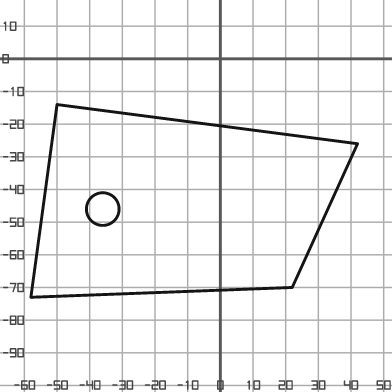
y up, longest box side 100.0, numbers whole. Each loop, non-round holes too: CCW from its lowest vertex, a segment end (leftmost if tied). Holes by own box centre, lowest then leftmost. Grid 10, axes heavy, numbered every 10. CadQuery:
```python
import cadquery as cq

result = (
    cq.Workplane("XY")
    .moveTo(-58.0, -73.0)
    .lineTo(22.0, -70.0)
    .lineTo(42.0, -26.0)
    .lineTo(-50.0, -14.0)
    .close()
    .moveTo(-36.0, -46.0)
    .circle(5.0)
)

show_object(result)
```